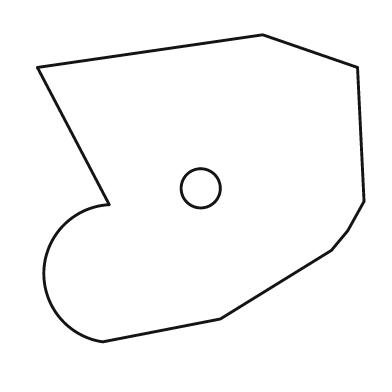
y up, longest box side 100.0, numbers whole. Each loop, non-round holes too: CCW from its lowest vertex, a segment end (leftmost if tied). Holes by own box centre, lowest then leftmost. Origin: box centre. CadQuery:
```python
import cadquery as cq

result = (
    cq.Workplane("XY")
    .moveTo(-30.0, -47.0)
    .lineTo(6.0, -40.0)
    .lineTo(40.0, -19.0)
    .lineTo(45.0, -13.0)
    .lineTo(50.0, -4.0)
    .lineTo(48.0, 37.0)
    .lineTo(19.0, 47.0)
    .lineTo(-50.0, 37.0)
    .lineTo(-28.0, -5.0)
    .threePointArc((-48.0, -25.0), (-30.0, -47.0))
    .close()
    .moveTo(0.0, 0.0)
    .circle(6.0)
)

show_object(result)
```